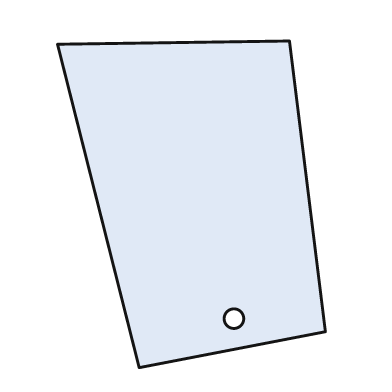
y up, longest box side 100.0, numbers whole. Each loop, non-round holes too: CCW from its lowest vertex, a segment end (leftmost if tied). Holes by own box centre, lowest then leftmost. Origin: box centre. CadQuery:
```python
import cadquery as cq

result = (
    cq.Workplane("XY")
    .moveTo(-16.0, -50.0)
    .lineTo(41.0, -39.0)
    .lineTo(30.0, 50.0)
    .lineTo(-41.0, 49.0)
    .close()
    .moveTo(13.0, -35.0)
    .circle(3.0)
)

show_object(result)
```